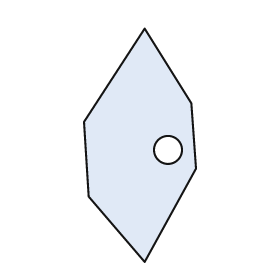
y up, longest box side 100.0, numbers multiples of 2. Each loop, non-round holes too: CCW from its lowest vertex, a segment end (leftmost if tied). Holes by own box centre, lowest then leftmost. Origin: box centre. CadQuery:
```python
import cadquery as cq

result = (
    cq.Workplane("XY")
    .moveTo(2.0, -50.0)
    .lineTo(24.0, -10.0)
    .lineTo(22.0, 18.0)
    .lineTo(2.0, 50.0)
    .lineTo(-24.0, 10.0)
    .lineTo(-22.0, -22.0)
    .close()
    .moveTo(12.0, -2.0)
    .circle(6.0)
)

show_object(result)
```